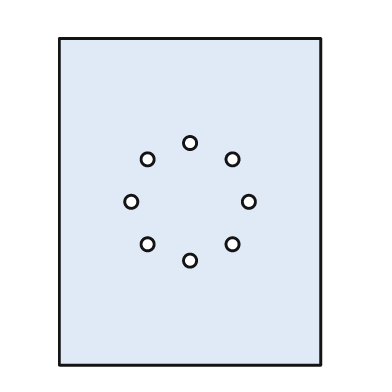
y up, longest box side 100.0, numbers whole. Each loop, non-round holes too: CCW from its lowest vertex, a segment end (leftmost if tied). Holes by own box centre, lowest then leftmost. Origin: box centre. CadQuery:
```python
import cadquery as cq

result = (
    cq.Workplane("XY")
    .moveTo(-40.0, -50.0)
    .lineTo(40.0, -50.0)
    .lineTo(40.0, 50.0)
    .lineTo(-40.0, 50.0)
    .close()
    .moveTo(0.0, -18.0)
    .circle(2.0)
    .moveTo(-13.0, -13.0)
    .circle(2.0)
    .moveTo(13.0, -13.0)
    .circle(2.0)
    .moveTo(-18.0, 0.0)
    .circle(2.0)
    .moveTo(18.0, 0.0)
    .circle(2.0)
    .moveTo(-13.0, 13.0)
    .circle(2.0)
    .moveTo(13.0, 13.0)
    .circle(2.0)
    .moveTo(0.0, 18.0)
    .circle(2.0)
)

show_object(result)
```